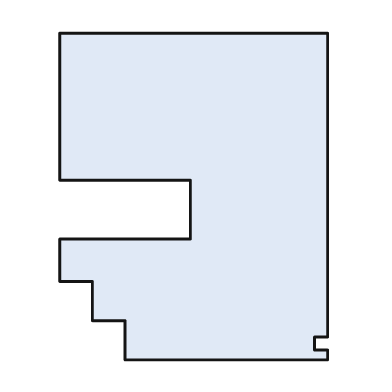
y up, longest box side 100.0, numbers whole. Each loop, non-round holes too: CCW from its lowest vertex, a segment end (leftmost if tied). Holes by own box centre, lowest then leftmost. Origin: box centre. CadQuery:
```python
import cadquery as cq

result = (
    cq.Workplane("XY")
    .moveTo(-21.0, -50.0)
    .lineTo(41.0, -50.0)
    .lineTo(41.0, -47.0)
    .lineTo(37.0, -47.0)
    .lineTo(37.0, -43.0)
    .lineTo(41.0, -43.0)
    .lineTo(41.0, 50.0)
    .lineTo(-41.0, 50.0)
    .lineTo(-41.0, 5.0)
    .lineTo(-1.0, 5.0)
    .lineTo(-1.0, -13.0)
    .lineTo(-41.0, -13.0)
    .lineTo(-41.0, -26.0)
    .lineTo(-31.0, -26.0)
    .lineTo(-31.0, -38.0)
    .lineTo(-21.0, -38.0)
    .close()
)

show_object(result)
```